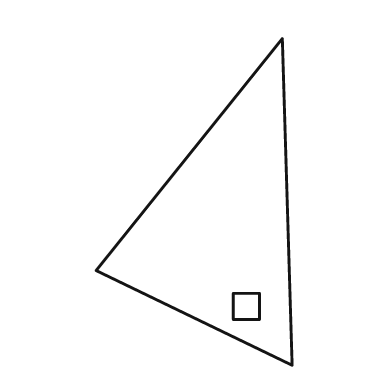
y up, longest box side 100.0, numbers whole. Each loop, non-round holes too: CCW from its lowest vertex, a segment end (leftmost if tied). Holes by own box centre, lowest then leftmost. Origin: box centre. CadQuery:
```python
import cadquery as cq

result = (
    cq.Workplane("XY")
    .moveTo(30.0, -50.0)
    .lineTo(27.0, 50.0)
    .lineTo(-30.0, -21.0)
    .close()
    .moveTo(12.0, -36.0)
    .lineTo(20.0, -36.0)
    .lineTo(20.0, -28.0)
    .lineTo(12.0, -28.0)
    .close()
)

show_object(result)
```